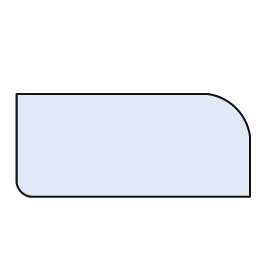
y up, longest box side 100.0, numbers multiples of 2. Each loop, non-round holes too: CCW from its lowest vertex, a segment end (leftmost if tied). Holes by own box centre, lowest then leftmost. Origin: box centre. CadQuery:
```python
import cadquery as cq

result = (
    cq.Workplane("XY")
    .moveTo(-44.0, -22.0)
    .lineTo(50.0, -22.0)
    .lineTo(50.0, 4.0)
    .threePointArc((44.0, 16.0), (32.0, 22.0))
    .lineTo(-50.0, 22.0)
    .lineTo(-50.0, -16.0)
    .threePointArc((-48.0, -20.0), (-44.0, -22.0))
    .close()
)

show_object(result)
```